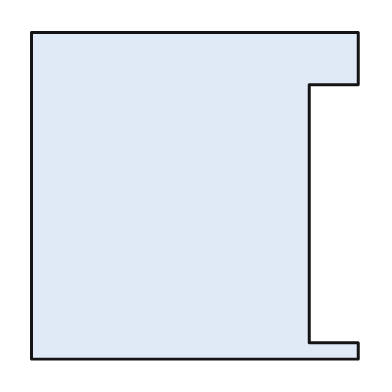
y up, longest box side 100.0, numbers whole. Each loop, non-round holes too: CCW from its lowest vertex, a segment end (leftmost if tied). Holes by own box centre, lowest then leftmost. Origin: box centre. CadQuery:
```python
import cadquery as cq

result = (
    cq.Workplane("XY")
    .moveTo(-50.0, -50.0)
    .lineTo(50.0, -50.0)
    .lineTo(50.0, -45.0)
    .lineTo(35.0, -45.0)
    .lineTo(35.0, 34.0)
    .lineTo(50.0, 34.0)
    .lineTo(50.0, 50.0)
    .lineTo(-50.0, 50.0)
    .close()
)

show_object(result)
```